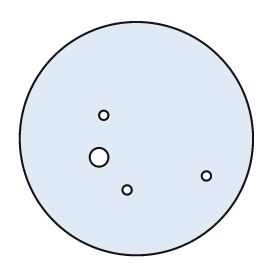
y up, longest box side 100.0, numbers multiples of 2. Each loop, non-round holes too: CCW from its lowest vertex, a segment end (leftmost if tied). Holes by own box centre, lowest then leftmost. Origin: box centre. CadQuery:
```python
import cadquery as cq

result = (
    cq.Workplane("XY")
    .moveTo(0.0, 0.0)
    .circle(50.0)
    .moveTo(-4.0, -22.0)
    .circle(2.0)
    .moveTo(30.0, -16.0)
    .circle(2.0)
    .moveTo(-16.0, -8.0)
    .circle(4.0)
    .moveTo(-14.0, 10.0)
    .circle(2.0)
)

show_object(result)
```